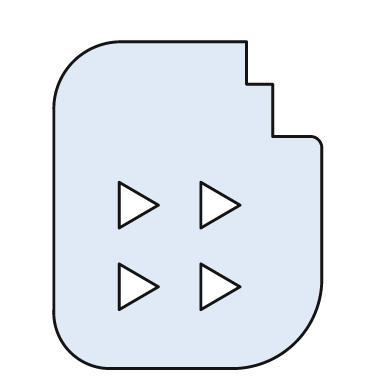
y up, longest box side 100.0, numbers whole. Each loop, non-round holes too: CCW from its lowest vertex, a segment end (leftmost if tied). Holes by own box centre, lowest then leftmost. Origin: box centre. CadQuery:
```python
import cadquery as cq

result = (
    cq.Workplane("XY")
    .moveTo(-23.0, -50.0)
    .lineTo(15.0, -50.0)
    .threePointArc((33.0, -42.0), (41.0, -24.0))
    .lineTo(41.0, 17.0)
    .threePointArc((40.0, 20.0), (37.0, 21.0))
    .lineTo(26.0, 21.0)
    .lineTo(26.0, 37.0)
    .lineTo(18.0, 37.0)
    .lineTo(18.0, 50.0)
    .lineTo(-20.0, 50.0)
    .threePointArc((-35.0, 44.0), (-41.0, 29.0))
    .lineTo(-41.0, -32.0)
    .threePointArc((-36.0, -45.0), (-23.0, -50.0))
    .close()
    .moveTo(-21.0, -32.0)
    .lineTo(-9.0, -25.0)
    .lineTo(-21.0, -18.0)
    .close()
    .moveTo(4.0, -32.0)
    .lineTo(16.0, -25.0)
    .lineTo(4.0, -18.0)
    .close()
    .moveTo(-21.0, -7.0)
    .lineTo(-9.0, 0.0)
    .lineTo(-21.0, 7.0)
    .close()
    .moveTo(4.0, -7.0)
    .lineTo(16.0, 0.0)
    .lineTo(4.0, 7.0)
    .close()
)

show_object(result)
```